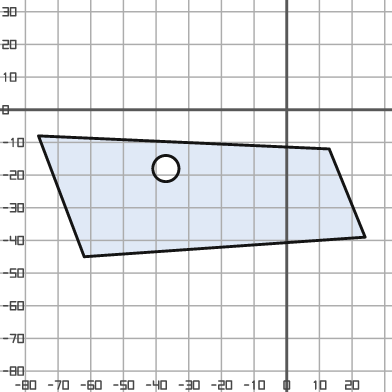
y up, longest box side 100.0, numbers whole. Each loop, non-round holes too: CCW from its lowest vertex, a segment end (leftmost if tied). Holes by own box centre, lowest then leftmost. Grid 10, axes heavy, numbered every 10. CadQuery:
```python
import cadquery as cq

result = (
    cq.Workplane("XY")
    .moveTo(-62.0, -45.0)
    .lineTo(24.0, -39.0)
    .lineTo(13.0, -12.0)
    .lineTo(-76.0, -8.0)
    .close()
    .moveTo(-37.0, -18.0)
    .circle(4.0)
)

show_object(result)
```